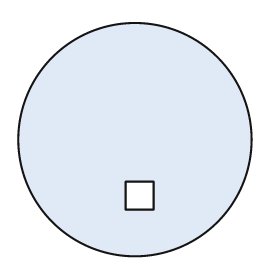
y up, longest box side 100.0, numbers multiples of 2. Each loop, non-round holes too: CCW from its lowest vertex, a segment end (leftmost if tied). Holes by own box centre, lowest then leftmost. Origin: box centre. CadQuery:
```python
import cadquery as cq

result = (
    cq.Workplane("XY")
    .moveTo(0.0, 0.0)
    .circle(50.0)
    .moveTo(-4.0, -30.0)
    .lineTo(8.0, -30.0)
    .lineTo(8.0, -18.0)
    .lineTo(-4.0, -18.0)
    .close()
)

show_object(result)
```